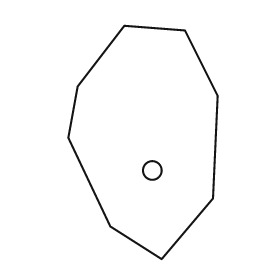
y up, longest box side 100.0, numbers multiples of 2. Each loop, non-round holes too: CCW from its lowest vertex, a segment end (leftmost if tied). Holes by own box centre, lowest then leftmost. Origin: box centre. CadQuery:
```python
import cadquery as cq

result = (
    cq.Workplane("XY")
    .moveTo(8.0, -50.0)
    .lineTo(30.0, -24.0)
    .lineTo(32.0, 20.0)
    .lineTo(18.0, 48.0)
    .lineTo(-8.0, 50.0)
    .lineTo(-28.0, 24.0)
    .lineTo(-32.0, 2.0)
    .lineTo(-14.0, -36.0)
    .close()
    .moveTo(4.0, -12.0)
    .circle(4.0)
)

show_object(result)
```